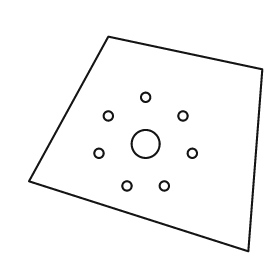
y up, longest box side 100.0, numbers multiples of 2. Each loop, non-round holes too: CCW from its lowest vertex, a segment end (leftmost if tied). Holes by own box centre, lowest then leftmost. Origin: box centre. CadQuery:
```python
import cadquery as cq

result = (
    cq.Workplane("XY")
    .moveTo(44.0, -46.0)
    .lineTo(50.0, 32.0)
    .lineTo(-16.0, 46.0)
    .lineTo(-50.0, -16.0)
    .close()
    .moveTo(-8.0, -18.0)
    .circle(2.0)
    .moveTo(8.0, -18.0)
    .circle(2.0)
    .moveTo(-20.0, -4.0)
    .circle(2.0)
    .moveTo(20.0, -4.0)
    .circle(2.0)
    .moveTo(0.0, 0.0)
    .circle(6.0)
    .moveTo(-16.0, 12.0)
    .circle(2.0)
    .moveTo(16.0, 12.0)
    .circle(2.0)
    .moveTo(0.0, 20.0)
    .circle(2.0)
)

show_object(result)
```